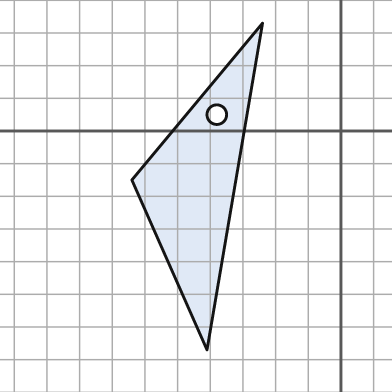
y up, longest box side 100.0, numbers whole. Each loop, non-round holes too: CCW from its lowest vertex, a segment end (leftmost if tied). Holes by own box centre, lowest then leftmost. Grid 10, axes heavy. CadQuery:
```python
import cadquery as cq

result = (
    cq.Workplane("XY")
    .moveTo(-41.0, -67.0)
    .lineTo(-24.0, 33.0)
    .lineTo(-64.0, -15.0)
    .close()
    .moveTo(-38.0, 5.0)
    .circle(3.0)
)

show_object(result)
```